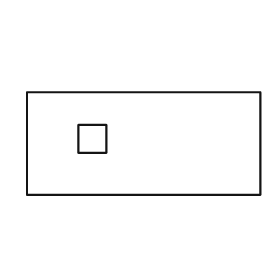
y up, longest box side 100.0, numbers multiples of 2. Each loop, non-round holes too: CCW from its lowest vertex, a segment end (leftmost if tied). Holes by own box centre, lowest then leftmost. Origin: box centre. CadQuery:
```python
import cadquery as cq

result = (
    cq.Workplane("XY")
    .moveTo(-50.0, -22.0)
    .lineTo(50.0, -22.0)
    .lineTo(50.0, 22.0)
    .lineTo(-50.0, 22.0)
    .close()
    .moveTo(-28.0, -4.0)
    .lineTo(-16.0, -4.0)
    .lineTo(-16.0, 8.0)
    .lineTo(-28.0, 8.0)
    .close()
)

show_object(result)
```